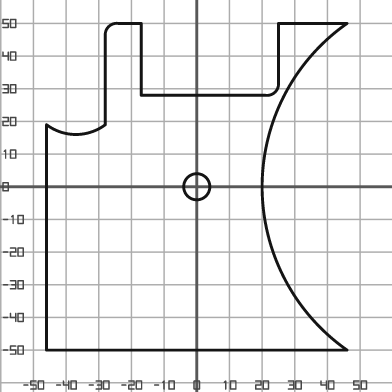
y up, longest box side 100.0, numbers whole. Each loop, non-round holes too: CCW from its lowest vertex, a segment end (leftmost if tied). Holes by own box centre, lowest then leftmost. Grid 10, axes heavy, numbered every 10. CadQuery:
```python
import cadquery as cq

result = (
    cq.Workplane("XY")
    .moveTo(-46.0, -50.0)
    .lineTo(46.0, -50.0)
    .threePointArc((20.0, 0.0), (46.0, 50.0))
    .lineTo(25.0, 50.0)
    .lineTo(25.0, 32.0)
    .threePointArc((24.0, 29.0), (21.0, 28.0))
    .lineTo(-17.0, 28.0)
    .lineTo(-17.0, 50.0)
    .lineTo(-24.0, 50.0)
    .threePointArc((-27.0, 49.0), (-28.0, 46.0))
    .lineTo(-28.0, 19.0)
    .threePointArc((-37.0, 16.0), (-46.0, 19.0))
    .close()
    .moveTo(0.0, 0.0)
    .circle(4.0)
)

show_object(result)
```